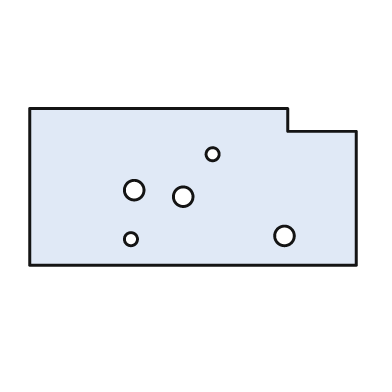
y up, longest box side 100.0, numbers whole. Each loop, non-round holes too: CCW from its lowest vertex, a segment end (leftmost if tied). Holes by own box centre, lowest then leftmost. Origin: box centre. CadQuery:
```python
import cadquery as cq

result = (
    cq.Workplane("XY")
    .moveTo(-50.0, -24.0)
    .lineTo(50.0, -24.0)
    .lineTo(50.0, 17.0)
    .lineTo(29.0, 17.0)
    .lineTo(29.0, 24.0)
    .lineTo(-50.0, 24.0)
    .close()
    .moveTo(-19.0, -16.0)
    .circle(2.0)
    .moveTo(28.0, -15.0)
    .circle(3.0)
    .moveTo(-3.0, -3.0)
    .circle(3.0)
    .moveTo(-18.0, -1.0)
    .circle(3.0)
    .moveTo(6.0, 10.0)
    .circle(2.0)
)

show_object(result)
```